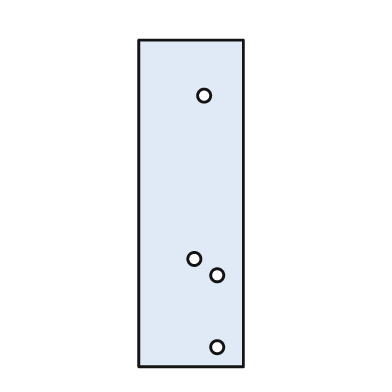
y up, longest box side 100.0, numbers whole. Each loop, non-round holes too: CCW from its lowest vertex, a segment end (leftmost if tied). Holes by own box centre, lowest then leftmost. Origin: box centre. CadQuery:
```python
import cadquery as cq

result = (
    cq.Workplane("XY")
    .moveTo(-16.0, -50.0)
    .lineTo(16.0, -50.0)
    .lineTo(16.0, 50.0)
    .lineTo(-16.0, 50.0)
    .close()
    .moveTo(8.0, -44.0)
    .circle(2.0)
    .moveTo(8.0, -22.0)
    .circle(2.0)
    .moveTo(1.0, -17.0)
    .circle(2.0)
    .moveTo(4.0, 33.0)
    .circle(2.0)
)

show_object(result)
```